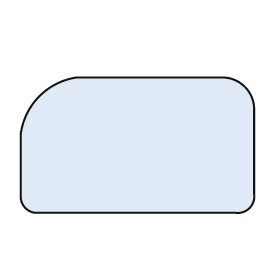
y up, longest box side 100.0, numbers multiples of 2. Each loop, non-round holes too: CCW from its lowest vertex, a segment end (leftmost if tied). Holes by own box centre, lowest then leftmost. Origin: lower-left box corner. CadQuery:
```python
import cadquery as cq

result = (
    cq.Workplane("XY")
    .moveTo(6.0, 0.0)
    .lineTo(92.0, 0.0)
    .threePointArc((98.0, 2.0), (100.0, 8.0))
    .lineTo(100.0, 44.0)
    .threePointArc((96.0, 54.0), (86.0, 58.0))
    .lineTo(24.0, 58.0)
    .threePointArc((8.0, 50.0), (0.0, 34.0))
    .lineTo(0.0, 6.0)
    .threePointArc((2.0, 2.0), (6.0, 0.0))
    .close()
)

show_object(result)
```